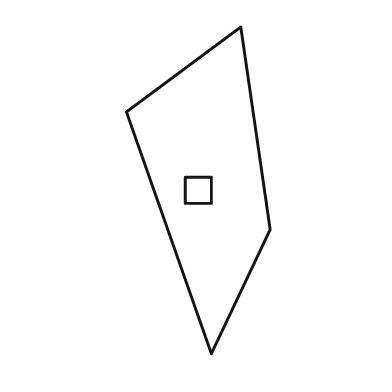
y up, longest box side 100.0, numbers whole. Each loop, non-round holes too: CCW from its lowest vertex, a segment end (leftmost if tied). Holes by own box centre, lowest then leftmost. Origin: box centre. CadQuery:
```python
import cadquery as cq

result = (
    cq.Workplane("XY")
    .moveTo(4.0, -50.0)
    .lineTo(22.0, -12.0)
    .lineTo(13.0, 50.0)
    .lineTo(-22.0, 24.0)
    .close()
    .moveTo(-4.0, -4.0)
    .lineTo(4.0, -4.0)
    .lineTo(4.0, 4.0)
    .lineTo(-4.0, 4.0)
    .close()
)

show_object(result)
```